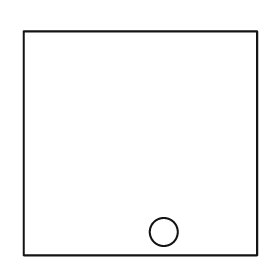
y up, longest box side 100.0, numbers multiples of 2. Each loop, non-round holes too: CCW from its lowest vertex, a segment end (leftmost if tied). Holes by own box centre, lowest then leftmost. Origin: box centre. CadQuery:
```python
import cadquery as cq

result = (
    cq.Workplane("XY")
    .moveTo(-50.0, -48.0)
    .lineTo(50.0, -48.0)
    .lineTo(50.0, 48.0)
    .lineTo(-50.0, 48.0)
    .close()
    .moveTo(10.0, -38.0)
    .circle(6.0)
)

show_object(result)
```